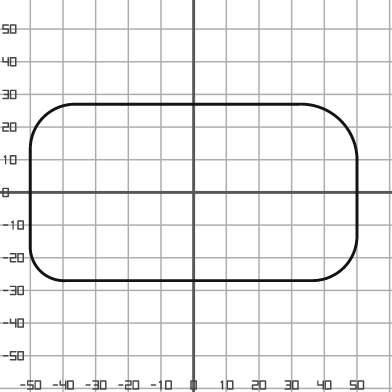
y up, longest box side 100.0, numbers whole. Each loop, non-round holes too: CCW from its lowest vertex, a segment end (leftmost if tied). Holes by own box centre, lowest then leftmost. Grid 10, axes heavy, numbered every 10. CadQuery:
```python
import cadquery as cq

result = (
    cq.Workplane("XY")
    .moveTo(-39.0, -27.0)
    .lineTo(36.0, -27.0)
    .threePointArc((46.0, -23.0), (50.0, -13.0))
    .lineTo(50.0, 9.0)
    .threePointArc((45.0, 22.0), (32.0, 27.0))
    .lineTo(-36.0, 27.0)
    .threePointArc((-46.0, 23.0), (-50.0, 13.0))
    .lineTo(-50.0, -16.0)
    .threePointArc((-47.0, -24.0), (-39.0, -27.0))
    .close()
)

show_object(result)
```